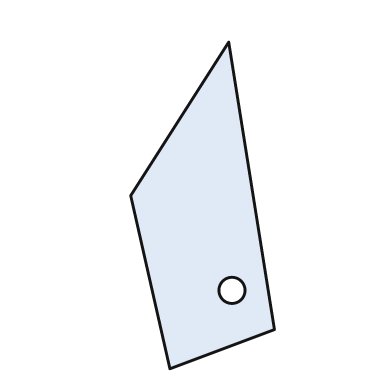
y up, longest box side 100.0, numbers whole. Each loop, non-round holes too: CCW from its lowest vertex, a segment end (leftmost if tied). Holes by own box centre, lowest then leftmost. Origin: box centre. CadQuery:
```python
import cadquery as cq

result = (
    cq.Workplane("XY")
    .moveTo(-10.0, -50.0)
    .lineTo(22.0, -38.0)
    .lineTo(8.0, 50.0)
    .lineTo(-22.0, 3.0)
    .close()
    .moveTo(9.0, -26.0)
    .circle(4.0)
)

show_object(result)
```